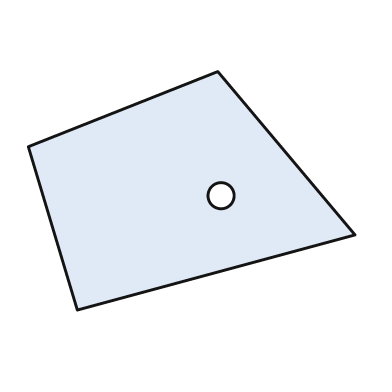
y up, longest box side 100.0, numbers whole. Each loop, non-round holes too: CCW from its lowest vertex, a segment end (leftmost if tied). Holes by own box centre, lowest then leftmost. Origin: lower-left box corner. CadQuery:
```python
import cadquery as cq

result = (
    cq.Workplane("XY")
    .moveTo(15.0, 0.0)
    .lineTo(100.0, 23.0)
    .lineTo(58.0, 73.0)
    .lineTo(0.0, 50.0)
    .close()
    .moveTo(59.0, 35.0)
    .circle(4.0)
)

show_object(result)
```